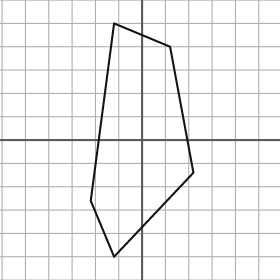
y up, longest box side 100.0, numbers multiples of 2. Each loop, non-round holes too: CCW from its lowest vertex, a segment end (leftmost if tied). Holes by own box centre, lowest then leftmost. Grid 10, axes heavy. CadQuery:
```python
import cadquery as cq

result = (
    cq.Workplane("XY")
    .moveTo(-12.0, -50.0)
    .lineTo(22.0, -14.0)
    .lineTo(12.0, 40.0)
    .lineTo(-12.0, 50.0)
    .lineTo(-22.0, -26.0)
    .close()
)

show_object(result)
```